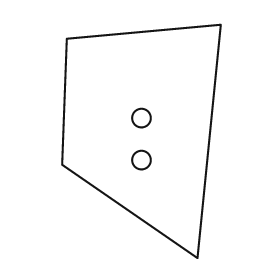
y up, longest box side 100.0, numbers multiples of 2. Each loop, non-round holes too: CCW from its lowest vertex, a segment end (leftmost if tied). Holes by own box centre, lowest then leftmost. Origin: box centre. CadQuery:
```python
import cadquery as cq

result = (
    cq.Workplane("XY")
    .moveTo(24.0, -50.0)
    .lineTo(34.0, 50.0)
    .lineTo(-32.0, 44.0)
    .lineTo(-34.0, -10.0)
    .close()
    .moveTo(0.0, -8.0)
    .circle(4.0)
    .moveTo(0.0, 10.0)
    .circle(4.0)
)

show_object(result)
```